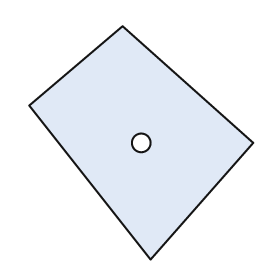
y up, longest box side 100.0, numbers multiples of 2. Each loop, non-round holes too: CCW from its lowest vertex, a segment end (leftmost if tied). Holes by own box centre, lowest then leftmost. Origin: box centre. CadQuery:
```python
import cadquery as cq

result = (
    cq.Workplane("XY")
    .moveTo(4.0, -50.0)
    .lineTo(48.0, 0.0)
    .lineTo(-8.0, 50.0)
    .lineTo(-48.0, 16.0)
    .close()
    .moveTo(0.0, 0.0)
    .circle(4.0)
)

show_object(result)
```